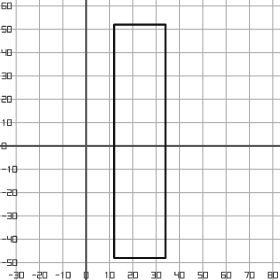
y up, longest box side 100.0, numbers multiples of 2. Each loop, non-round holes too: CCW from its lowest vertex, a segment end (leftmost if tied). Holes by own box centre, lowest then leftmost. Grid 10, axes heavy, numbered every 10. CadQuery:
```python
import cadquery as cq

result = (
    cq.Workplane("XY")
    .moveTo(12.0, -48.0)
    .lineTo(34.0, -48.0)
    .lineTo(34.0, 52.0)
    .lineTo(12.0, 52.0)
    .close()
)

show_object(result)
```